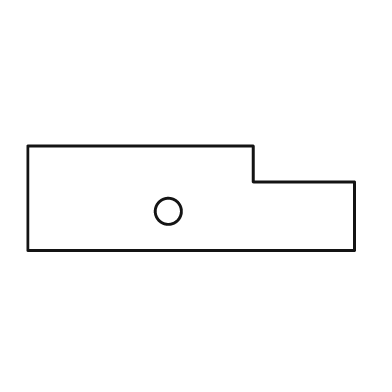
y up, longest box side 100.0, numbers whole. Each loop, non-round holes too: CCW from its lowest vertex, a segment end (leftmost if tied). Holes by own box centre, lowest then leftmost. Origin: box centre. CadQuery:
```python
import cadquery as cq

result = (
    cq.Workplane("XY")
    .moveTo(-50.0, -16.0)
    .lineTo(50.0, -16.0)
    .lineTo(50.0, 5.0)
    .lineTo(19.0, 5.0)
    .lineTo(19.0, 16.0)
    .lineTo(-50.0, 16.0)
    .close()
    .moveTo(-7.0, -4.0)
    .circle(4.0)
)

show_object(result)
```